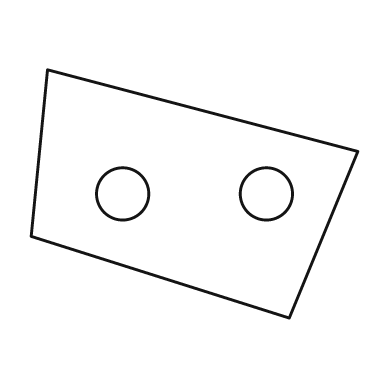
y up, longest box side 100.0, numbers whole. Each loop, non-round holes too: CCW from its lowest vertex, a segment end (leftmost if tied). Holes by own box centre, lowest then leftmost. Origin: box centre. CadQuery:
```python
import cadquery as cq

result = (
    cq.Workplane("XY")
    .moveTo(29.0, -38.0)
    .lineTo(50.0, 13.0)
    .lineTo(-45.0, 38.0)
    .lineTo(-50.0, -13.0)
    .close()
    .moveTo(-22.0, 0.0)
    .circle(8.0)
    .moveTo(22.0, 0.0)
    .circle(8.0)
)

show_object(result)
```